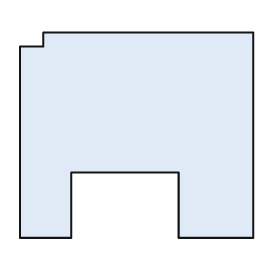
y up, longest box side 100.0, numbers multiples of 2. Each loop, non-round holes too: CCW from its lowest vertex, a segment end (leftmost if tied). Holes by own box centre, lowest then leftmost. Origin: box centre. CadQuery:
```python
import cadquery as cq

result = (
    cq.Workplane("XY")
    .moveTo(-50.0, -44.0)
    .lineTo(-28.0, -44.0)
    .lineTo(-28.0, -16.0)
    .lineTo(18.0, -16.0)
    .lineTo(18.0, -44.0)
    .lineTo(50.0, -44.0)
    .lineTo(50.0, 44.0)
    .lineTo(-40.0, 44.0)
    .lineTo(-40.0, 38.0)
    .lineTo(-50.0, 38.0)
    .close()
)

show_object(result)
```